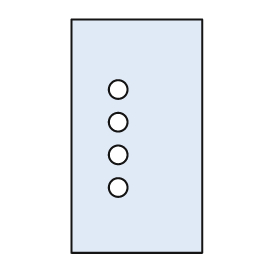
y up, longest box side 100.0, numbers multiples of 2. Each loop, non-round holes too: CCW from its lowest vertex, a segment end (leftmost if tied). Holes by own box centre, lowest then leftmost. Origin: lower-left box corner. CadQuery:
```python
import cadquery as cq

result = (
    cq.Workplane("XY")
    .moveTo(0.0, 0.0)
    .lineTo(56.0, 0.0)
    .lineTo(56.0, 100.0)
    .lineTo(0.0, 100.0)
    .close()
    .moveTo(20.0, 28.0)
    .circle(4.0)
    .moveTo(20.0, 42.0)
    .circle(4.0)
    .moveTo(20.0, 56.0)
    .circle(4.0)
    .moveTo(20.0, 70.0)
    .circle(4.0)
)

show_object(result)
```